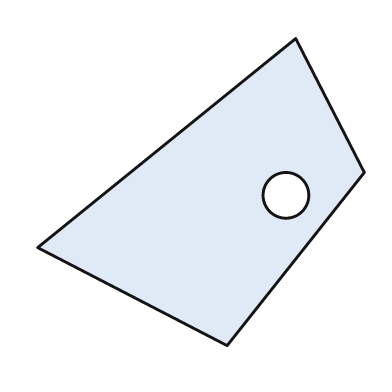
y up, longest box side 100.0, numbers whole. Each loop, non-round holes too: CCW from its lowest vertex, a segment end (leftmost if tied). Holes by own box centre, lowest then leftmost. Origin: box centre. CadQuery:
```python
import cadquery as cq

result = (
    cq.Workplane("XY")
    .moveTo(8.0, -47.0)
    .lineTo(50.0, 6.0)
    .lineTo(29.0, 47.0)
    .lineTo(-50.0, -17.0)
    .close()
    .moveTo(26.0, -1.0)
    .circle(7.0)
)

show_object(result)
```